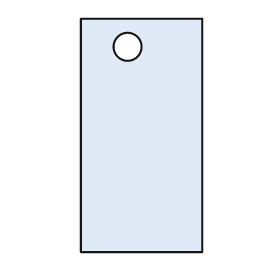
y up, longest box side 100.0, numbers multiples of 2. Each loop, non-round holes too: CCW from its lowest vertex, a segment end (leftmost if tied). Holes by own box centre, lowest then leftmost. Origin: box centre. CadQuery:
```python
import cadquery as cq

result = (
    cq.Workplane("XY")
    .moveTo(-26.0, -50.0)
    .lineTo(26.0, -50.0)
    .lineTo(26.0, 50.0)
    .lineTo(-26.0, 50.0)
    .close()
    .moveTo(-6.0, 38.0)
    .circle(6.0)
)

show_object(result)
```